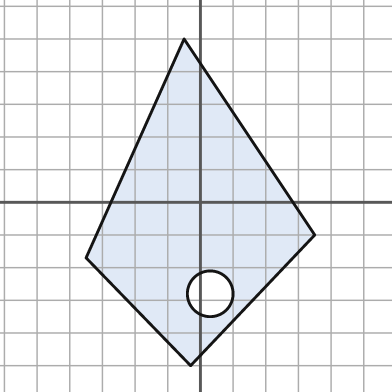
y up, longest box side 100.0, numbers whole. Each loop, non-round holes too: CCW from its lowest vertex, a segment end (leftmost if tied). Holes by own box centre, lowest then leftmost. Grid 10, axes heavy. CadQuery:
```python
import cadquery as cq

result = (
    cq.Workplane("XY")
    .moveTo(-3.0, -50.0)
    .lineTo(35.0, -10.0)
    .lineTo(-5.0, 50.0)
    .lineTo(-35.0, -17.0)
    .close()
    .moveTo(3.0, -28.0)
    .circle(7.0)
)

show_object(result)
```